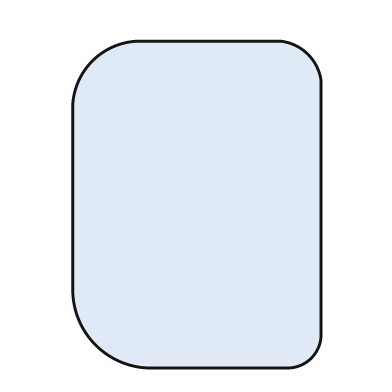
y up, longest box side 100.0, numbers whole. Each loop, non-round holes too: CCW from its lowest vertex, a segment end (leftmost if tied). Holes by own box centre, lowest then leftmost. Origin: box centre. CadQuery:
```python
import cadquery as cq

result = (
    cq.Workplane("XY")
    .moveTo(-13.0, -50.0)
    .lineTo(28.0, -50.0)
    .threePointArc((35.0, -47.0), (38.0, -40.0))
    .lineTo(38.0, 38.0)
    .threePointArc((34.0, 46.0), (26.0, 50.0))
    .lineTo(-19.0, 50.0)
    .threePointArc((-32.0, 44.0), (-38.0, 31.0))
    .lineTo(-38.0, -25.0)
    .threePointArc((-31.0, -43.0), (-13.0, -50.0))
    .close()
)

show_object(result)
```